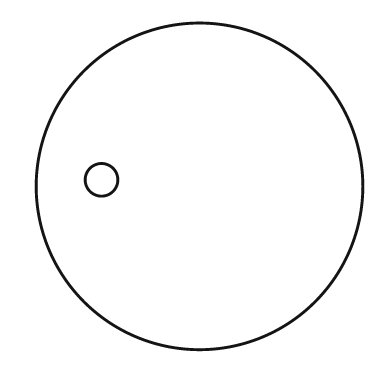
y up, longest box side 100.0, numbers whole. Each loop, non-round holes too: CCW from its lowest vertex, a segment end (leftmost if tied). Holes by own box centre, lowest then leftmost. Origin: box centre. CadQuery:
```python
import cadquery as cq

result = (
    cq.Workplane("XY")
    .moveTo(0.0, 0.0)
    .circle(50.0)
    .moveTo(-30.0, 2.0)
    .circle(5.0)
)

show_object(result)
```